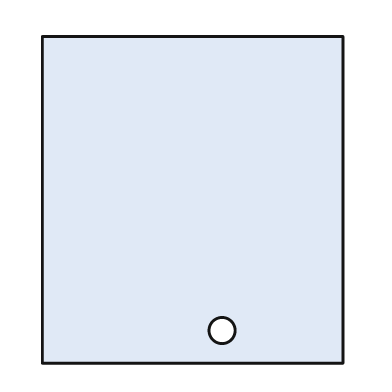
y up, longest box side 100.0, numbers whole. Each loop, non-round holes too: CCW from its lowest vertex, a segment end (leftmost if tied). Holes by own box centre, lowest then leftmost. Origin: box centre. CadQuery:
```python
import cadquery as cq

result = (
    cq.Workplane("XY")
    .moveTo(-46.0, -50.0)
    .lineTo(46.0, -50.0)
    .lineTo(46.0, 50.0)
    .lineTo(-46.0, 50.0)
    .close()
    .moveTo(9.0, -40.0)
    .circle(4.0)
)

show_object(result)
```